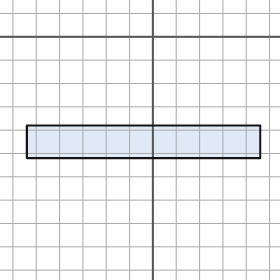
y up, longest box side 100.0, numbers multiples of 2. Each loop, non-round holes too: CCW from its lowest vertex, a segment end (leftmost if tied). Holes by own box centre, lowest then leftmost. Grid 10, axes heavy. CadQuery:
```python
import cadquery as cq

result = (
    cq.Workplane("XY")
    .moveTo(-54.0, -52.0)
    .lineTo(46.0, -52.0)
    .lineTo(46.0, -38.0)
    .lineTo(-54.0, -38.0)
    .close()
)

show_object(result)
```